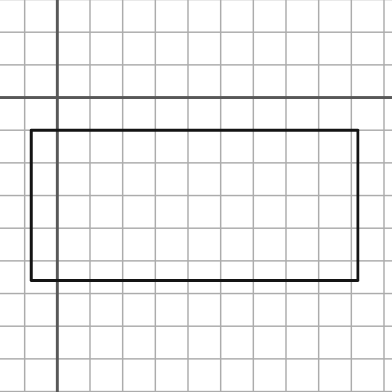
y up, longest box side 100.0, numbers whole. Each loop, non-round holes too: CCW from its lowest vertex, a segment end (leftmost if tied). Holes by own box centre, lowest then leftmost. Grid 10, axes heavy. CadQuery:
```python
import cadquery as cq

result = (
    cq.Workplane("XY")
    .moveTo(-8.0, -56.0)
    .lineTo(92.0, -56.0)
    .lineTo(92.0, -10.0)
    .lineTo(-8.0, -10.0)
    .close()
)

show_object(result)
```